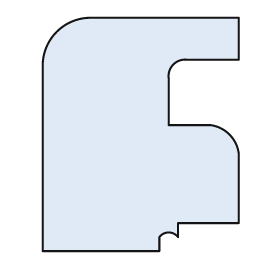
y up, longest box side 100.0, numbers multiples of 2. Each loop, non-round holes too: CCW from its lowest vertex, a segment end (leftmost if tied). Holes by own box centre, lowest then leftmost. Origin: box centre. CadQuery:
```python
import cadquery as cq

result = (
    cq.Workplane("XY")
    .moveTo(-42.0, -50.0)
    .lineTo(8.0, -50.0)
    .lineTo(8.0, -44.0)
    .threePointArc((12.0, -42.0), (16.0, -44.0))
    .lineTo(16.0, -38.0)
    .lineTo(42.0, -38.0)
    .lineTo(42.0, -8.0)
    .threePointArc((38.0, 0.0), (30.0, 4.0))
    .lineTo(12.0, 4.0)
    .lineTo(12.0, 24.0)
    .threePointArc((14.0, 30.0), (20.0, 32.0))
    .lineTo(42.0, 32.0)
    .lineTo(42.0, 50.0)
    .lineTo(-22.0, 50.0)
    .threePointArc((-36.0, 44.0), (-42.0, 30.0))
    .close()
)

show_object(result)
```